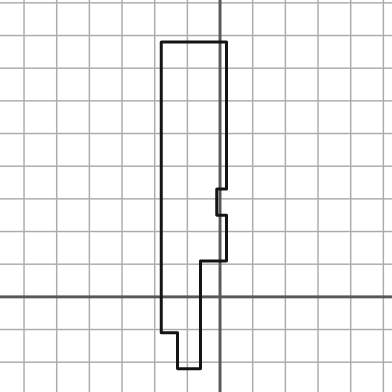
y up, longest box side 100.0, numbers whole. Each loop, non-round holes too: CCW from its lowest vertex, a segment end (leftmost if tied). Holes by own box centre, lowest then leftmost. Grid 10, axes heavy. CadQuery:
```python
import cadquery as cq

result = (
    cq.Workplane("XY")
    .moveTo(-13.0, -22.0)
    .lineTo(-6.0, -22.0)
    .lineTo(-6.0, 11.0)
    .lineTo(2.0, 11.0)
    .lineTo(2.0, 25.0)
    .lineTo(-1.0, 25.0)
    .lineTo(-1.0, 33.0)
    .lineTo(2.0, 33.0)
    .lineTo(2.0, 78.0)
    .lineTo(-18.0, 78.0)
    .lineTo(-18.0, -11.0)
    .lineTo(-13.0, -11.0)
    .close()
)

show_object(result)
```